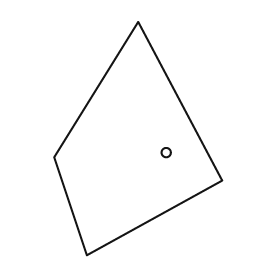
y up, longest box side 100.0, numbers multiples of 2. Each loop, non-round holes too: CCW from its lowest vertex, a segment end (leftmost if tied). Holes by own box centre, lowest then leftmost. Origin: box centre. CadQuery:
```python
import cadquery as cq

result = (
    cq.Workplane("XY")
    .moveTo(-22.0, -50.0)
    .lineTo(36.0, -18.0)
    .lineTo(0.0, 50.0)
    .lineTo(-36.0, -8.0)
    .close()
    .moveTo(12.0, -6.0)
    .circle(2.0)
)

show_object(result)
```